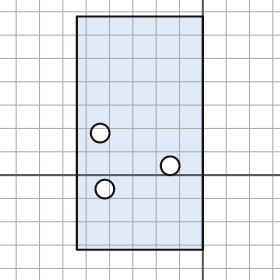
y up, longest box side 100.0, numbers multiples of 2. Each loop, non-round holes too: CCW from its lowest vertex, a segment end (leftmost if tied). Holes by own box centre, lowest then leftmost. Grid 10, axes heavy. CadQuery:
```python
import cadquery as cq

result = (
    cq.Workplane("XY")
    .moveTo(-54.0, -32.0)
    .lineTo(0.0, -32.0)
    .lineTo(0.0, 68.0)
    .lineTo(-54.0, 68.0)
    .close()
    .moveTo(-42.0, -6.0)
    .circle(4.0)
    .moveTo(-14.0, 4.0)
    .circle(4.0)
    .moveTo(-44.0, 18.0)
    .circle(4.0)
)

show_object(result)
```